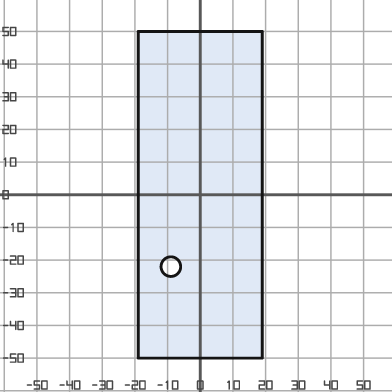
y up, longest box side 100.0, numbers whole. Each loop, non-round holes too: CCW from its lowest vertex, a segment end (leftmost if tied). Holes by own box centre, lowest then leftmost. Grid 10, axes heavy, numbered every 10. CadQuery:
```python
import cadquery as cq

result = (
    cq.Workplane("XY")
    .moveTo(-19.0, -50.0)
    .lineTo(19.0, -50.0)
    .lineTo(19.0, 50.0)
    .lineTo(-19.0, 50.0)
    .close()
    .moveTo(-9.0, -22.0)
    .circle(3.0)
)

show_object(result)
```